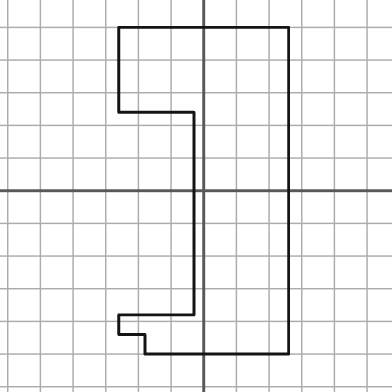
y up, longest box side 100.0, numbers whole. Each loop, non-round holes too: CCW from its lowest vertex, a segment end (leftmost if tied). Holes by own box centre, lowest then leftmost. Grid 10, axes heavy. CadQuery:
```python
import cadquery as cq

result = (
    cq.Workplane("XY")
    .moveTo(-18.0, -50.0)
    .lineTo(26.0, -50.0)
    .lineTo(26.0, 50.0)
    .lineTo(-26.0, 50.0)
    .lineTo(-26.0, 24.0)
    .lineTo(-3.0, 24.0)
    .lineTo(-3.0, -38.0)
    .lineTo(-26.0, -38.0)
    .lineTo(-26.0, -44.0)
    .lineTo(-18.0, -44.0)
    .close()
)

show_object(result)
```